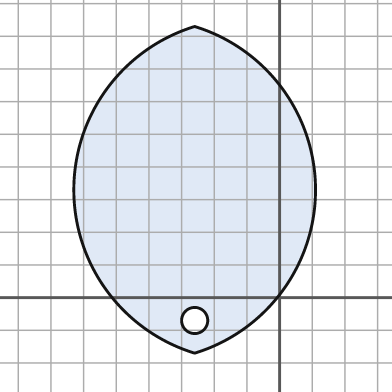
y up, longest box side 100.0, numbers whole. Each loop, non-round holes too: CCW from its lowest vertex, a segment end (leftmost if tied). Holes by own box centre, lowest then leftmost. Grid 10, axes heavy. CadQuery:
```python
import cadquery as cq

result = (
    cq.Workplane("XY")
    .moveTo(-26.0, -17.0)
    .threePointArc((11.0, 33.0), (-26.0, 83.0))
    .threePointArc((-63.0, 33.0), (-26.0, -17.0))
    .close()
    .moveTo(-26.0, -7.0)
    .circle(4.0)
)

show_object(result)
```